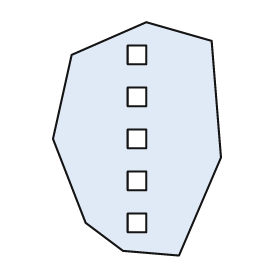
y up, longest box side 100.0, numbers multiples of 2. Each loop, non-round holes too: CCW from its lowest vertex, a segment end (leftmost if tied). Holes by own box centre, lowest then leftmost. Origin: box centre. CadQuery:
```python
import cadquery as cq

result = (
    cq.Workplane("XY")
    .moveTo(18.0, -50.0)
    .lineTo(36.0, -8.0)
    .lineTo(32.0, 42.0)
    .lineTo(4.0, 50.0)
    .lineTo(-28.0, 36.0)
    .lineTo(-36.0, 0.0)
    .lineTo(-22.0, -36.0)
    .lineTo(-6.0, -48.0)
    .close()
    .moveTo(-4.0, -40.0)
    .lineTo(4.0, -40.0)
    .lineTo(4.0, -32.0)
    .lineTo(-4.0, -32.0)
    .close()
    .moveTo(-4.0, -22.0)
    .lineTo(4.0, -22.0)
    .lineTo(4.0, -14.0)
    .lineTo(-4.0, -14.0)
    .close()
    .moveTo(-4.0, -4.0)
    .lineTo(4.0, -4.0)
    .lineTo(4.0, 4.0)
    .lineTo(-4.0, 4.0)
    .close()
    .moveTo(-4.0, 14.0)
    .lineTo(4.0, 14.0)
    .lineTo(4.0, 22.0)
    .lineTo(-4.0, 22.0)
    .close()
    .moveTo(-4.0, 32.0)
    .lineTo(4.0, 32.0)
    .lineTo(4.0, 40.0)
    .lineTo(-4.0, 40.0)
    .close()
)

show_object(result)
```